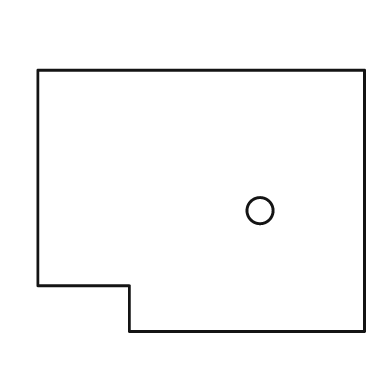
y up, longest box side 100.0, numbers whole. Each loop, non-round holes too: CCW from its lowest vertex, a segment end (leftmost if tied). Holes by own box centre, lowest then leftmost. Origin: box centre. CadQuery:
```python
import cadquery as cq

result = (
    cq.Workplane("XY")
    .moveTo(-22.0, -40.0)
    .lineTo(50.0, -40.0)
    .lineTo(50.0, 40.0)
    .lineTo(-50.0, 40.0)
    .lineTo(-50.0, -26.0)
    .lineTo(-22.0, -26.0)
    .close()
    .moveTo(18.0, -3.0)
    .circle(4.0)
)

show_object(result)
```